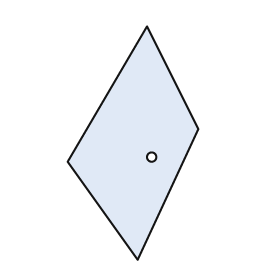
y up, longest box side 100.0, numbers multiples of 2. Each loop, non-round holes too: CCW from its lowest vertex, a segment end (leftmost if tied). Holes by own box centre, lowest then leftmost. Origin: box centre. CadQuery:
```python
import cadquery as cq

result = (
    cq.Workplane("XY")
    .moveTo(2.0, -50.0)
    .lineTo(28.0, 6.0)
    .lineTo(6.0, 50.0)
    .lineTo(-28.0, -8.0)
    .close()
    .moveTo(8.0, -6.0)
    .circle(2.0)
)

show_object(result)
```